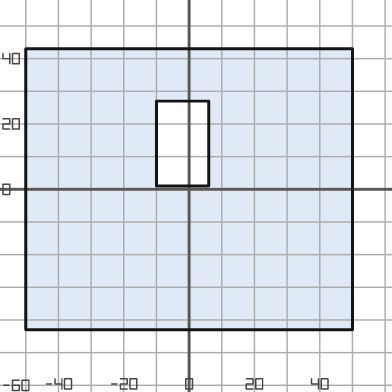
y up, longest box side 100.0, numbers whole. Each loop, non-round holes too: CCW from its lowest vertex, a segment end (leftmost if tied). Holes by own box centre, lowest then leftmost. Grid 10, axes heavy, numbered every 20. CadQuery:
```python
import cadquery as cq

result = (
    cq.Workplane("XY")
    .moveTo(-50.0, -43.0)
    .lineTo(50.0, -43.0)
    .lineTo(50.0, 43.0)
    .lineTo(-50.0, 43.0)
    .close()
    .moveTo(-10.0, 1.0)
    .lineTo(6.0, 1.0)
    .lineTo(6.0, 27.0)
    .lineTo(-10.0, 27.0)
    .close()
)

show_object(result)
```